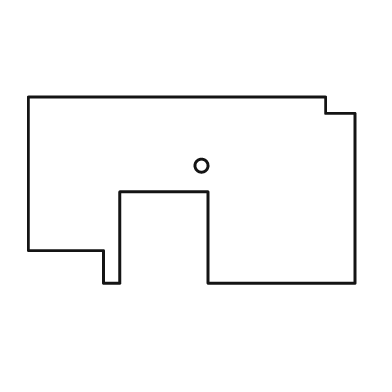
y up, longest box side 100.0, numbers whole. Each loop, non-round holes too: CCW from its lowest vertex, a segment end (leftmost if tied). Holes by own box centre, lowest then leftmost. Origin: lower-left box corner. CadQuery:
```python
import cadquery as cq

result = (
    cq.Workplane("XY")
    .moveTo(23.0, 0.0)
    .lineTo(28.0, 0.0)
    .lineTo(28.0, 28.0)
    .lineTo(55.0, 28.0)
    .lineTo(55.0, 0.0)
    .lineTo(100.0, 0.0)
    .lineTo(100.0, 52.0)
    .lineTo(91.0, 52.0)
    .lineTo(91.0, 57.0)
    .lineTo(0.0, 57.0)
    .lineTo(0.0, 10.0)
    .lineTo(23.0, 10.0)
    .close()
    .moveTo(53.0, 36.0)
    .circle(2.0)
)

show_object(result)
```